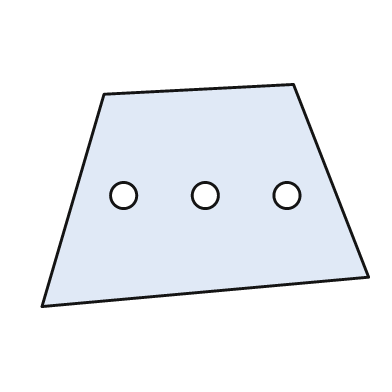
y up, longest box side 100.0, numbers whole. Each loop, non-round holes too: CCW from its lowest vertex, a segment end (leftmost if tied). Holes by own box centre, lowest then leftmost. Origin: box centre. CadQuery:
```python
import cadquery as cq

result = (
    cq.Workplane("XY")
    .moveTo(-50.0, -34.0)
    .lineTo(50.0, -25.0)
    .lineTo(27.0, 34.0)
    .lineTo(-31.0, 31.0)
    .close()
    .moveTo(-25.0, 0.0)
    .circle(4.0)
    .moveTo(0.0, 0.0)
    .circle(4.0)
    .moveTo(25.0, 0.0)
    .circle(4.0)
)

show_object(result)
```